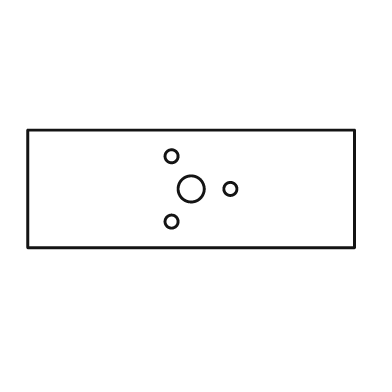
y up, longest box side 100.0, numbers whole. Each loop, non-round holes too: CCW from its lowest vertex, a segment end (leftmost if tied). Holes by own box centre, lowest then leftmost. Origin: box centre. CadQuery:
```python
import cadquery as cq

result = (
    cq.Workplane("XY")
    .moveTo(-50.0, -18.0)
    .lineTo(50.0, -18.0)
    .lineTo(50.0, 18.0)
    .lineTo(-50.0, 18.0)
    .close()
    .moveTo(-6.0, -10.0)
    .circle(2.0)
    .moveTo(0.0, 0.0)
    .circle(4.0)
    .moveTo(12.0, 0.0)
    .circle(2.0)
    .moveTo(-6.0, 10.0)
    .circle(2.0)
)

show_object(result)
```